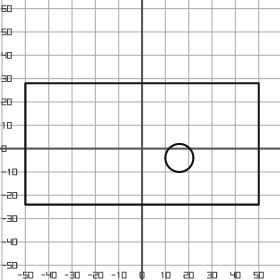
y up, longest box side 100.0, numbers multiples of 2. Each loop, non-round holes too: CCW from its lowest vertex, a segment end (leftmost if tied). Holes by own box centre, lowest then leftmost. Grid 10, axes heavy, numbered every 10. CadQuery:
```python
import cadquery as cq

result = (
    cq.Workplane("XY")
    .moveTo(-50.0, -24.0)
    .lineTo(50.0, -24.0)
    .lineTo(50.0, 28.0)
    .lineTo(-50.0, 28.0)
    .close()
    .moveTo(16.0, -4.0)
    .circle(6.0)
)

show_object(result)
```